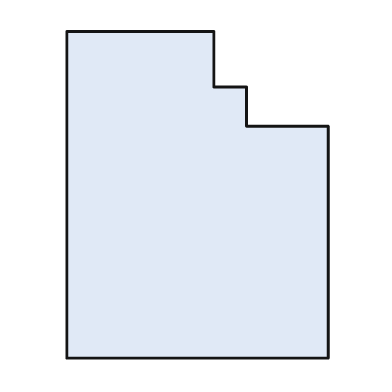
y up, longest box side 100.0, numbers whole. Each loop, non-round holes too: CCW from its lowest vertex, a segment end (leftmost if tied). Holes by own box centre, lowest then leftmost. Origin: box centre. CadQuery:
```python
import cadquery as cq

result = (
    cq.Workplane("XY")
    .moveTo(-40.0, -50.0)
    .lineTo(40.0, -50.0)
    .lineTo(40.0, 21.0)
    .lineTo(15.0, 21.0)
    .lineTo(15.0, 33.0)
    .lineTo(5.0, 33.0)
    .lineTo(5.0, 50.0)
    .lineTo(-40.0, 50.0)
    .close()
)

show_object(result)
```